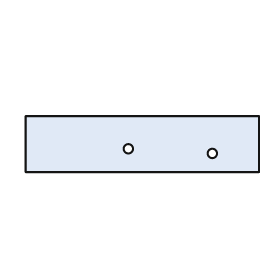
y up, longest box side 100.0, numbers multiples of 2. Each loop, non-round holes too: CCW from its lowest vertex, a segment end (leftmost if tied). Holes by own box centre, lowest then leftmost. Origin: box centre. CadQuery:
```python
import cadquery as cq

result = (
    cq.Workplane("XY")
    .moveTo(-50.0, -12.0)
    .lineTo(50.0, -12.0)
    .lineTo(50.0, 12.0)
    .lineTo(-50.0, 12.0)
    .close()
    .moveTo(30.0, -4.0)
    .circle(2.0)
    .moveTo(-6.0, -2.0)
    .circle(2.0)
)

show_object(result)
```